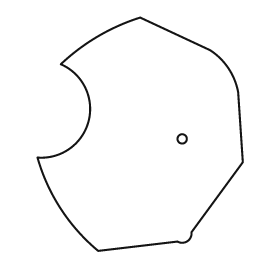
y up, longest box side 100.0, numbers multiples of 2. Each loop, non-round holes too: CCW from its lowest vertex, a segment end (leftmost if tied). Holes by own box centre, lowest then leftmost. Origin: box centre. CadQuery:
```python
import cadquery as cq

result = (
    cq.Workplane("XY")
    .moveTo(-18.0, -50.0)
    .lineTo(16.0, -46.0)
    .threePointArc((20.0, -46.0), (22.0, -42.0))
    .lineTo(44.0, -12.0)
    .lineTo(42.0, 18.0)
    .threePointArc((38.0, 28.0), (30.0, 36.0))
    .lineTo(0.0, 50.0)
    .threePointArc((-18.0, 42.0), (-34.0, 30.0))
    .threePointArc((-22.0, 6.0), (-44.0, -10.0))
    .threePointArc((-34.0, -32.0), (-18.0, -50.0))
    .close()
    .moveTo(18.0, -2.0)
    .circle(2.0)
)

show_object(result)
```